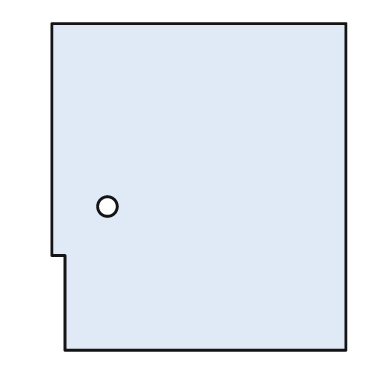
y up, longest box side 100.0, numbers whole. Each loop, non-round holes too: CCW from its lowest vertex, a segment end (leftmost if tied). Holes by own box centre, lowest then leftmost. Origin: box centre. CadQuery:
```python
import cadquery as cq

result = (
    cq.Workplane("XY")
    .moveTo(-41.0, -50.0)
    .lineTo(45.0, -50.0)
    .lineTo(45.0, 50.0)
    .lineTo(-45.0, 50.0)
    .lineTo(-45.0, -21.0)
    .lineTo(-41.0, -21.0)
    .close()
    .moveTo(-28.0, -6.0)
    .circle(3.0)
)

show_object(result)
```